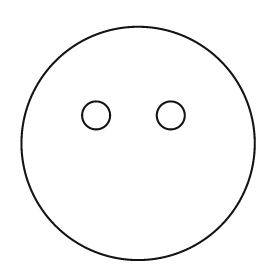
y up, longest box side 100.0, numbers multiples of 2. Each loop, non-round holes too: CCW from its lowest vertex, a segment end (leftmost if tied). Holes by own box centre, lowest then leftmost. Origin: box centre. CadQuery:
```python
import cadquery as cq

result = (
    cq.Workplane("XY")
    .moveTo(0.0, 0.0)
    .circle(50.0)
    .moveTo(-18.0, 12.0)
    .circle(6.0)
    .moveTo(14.0, 12.0)
    .circle(6.0)
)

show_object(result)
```